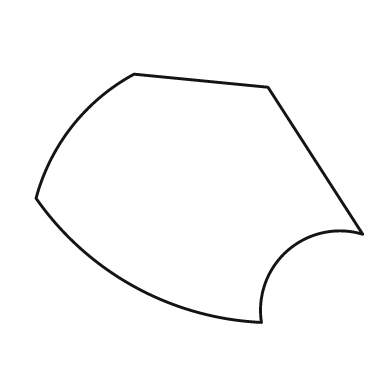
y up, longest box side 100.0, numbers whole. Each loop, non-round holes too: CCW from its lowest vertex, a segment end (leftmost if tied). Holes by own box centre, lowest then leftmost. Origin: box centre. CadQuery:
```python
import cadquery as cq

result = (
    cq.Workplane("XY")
    .moveTo(19.0, -38.0)
    .threePointArc((27.0, -16.0), (50.0, -11.0))
    .lineTo(21.0, 34.0)
    .lineTo(-20.0, 38.0)
    .threePointArc((-39.0, 22.0), (-50.0, 0.0))
    .threePointArc((-20.0, -27.0), (19.0, -38.0))
    .close()
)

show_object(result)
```